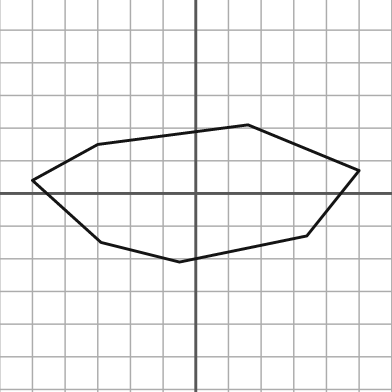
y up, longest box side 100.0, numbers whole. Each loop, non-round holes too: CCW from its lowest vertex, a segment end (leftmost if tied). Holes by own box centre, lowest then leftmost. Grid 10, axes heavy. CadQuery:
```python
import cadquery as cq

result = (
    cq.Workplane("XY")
    .moveTo(-5.0, -21.0)
    .lineTo(34.0, -13.0)
    .lineTo(50.0, 7.0)
    .lineTo(16.0, 21.0)
    .lineTo(-30.0, 15.0)
    .lineTo(-50.0, 4.0)
    .lineTo(-29.0, -15.0)
    .close()
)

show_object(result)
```